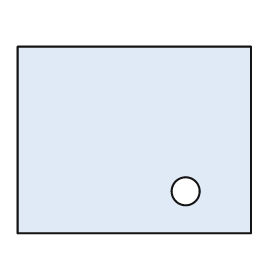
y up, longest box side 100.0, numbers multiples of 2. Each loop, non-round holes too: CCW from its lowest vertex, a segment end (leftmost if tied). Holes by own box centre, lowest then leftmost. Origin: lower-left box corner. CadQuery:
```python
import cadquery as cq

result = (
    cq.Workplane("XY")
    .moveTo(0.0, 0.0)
    .lineTo(100.0, 0.0)
    .lineTo(100.0, 80.0)
    .lineTo(0.0, 80.0)
    .close()
    .moveTo(72.0, 18.0)
    .circle(6.0)
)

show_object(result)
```